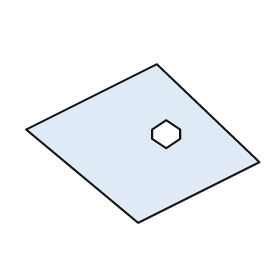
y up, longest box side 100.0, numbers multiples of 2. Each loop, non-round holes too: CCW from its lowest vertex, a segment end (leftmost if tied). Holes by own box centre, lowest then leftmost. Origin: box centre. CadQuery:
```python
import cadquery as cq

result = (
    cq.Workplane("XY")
    .moveTo(-2.0, -34.0)
    .lineTo(50.0, -8.0)
    .lineTo(6.0, 34.0)
    .lineTo(-50.0, 6.0)
    .close()
    .moveTo(10.0, -2.0)
    .lineTo(16.0, 2.0)
    .lineTo(16.0, 6.0)
    .lineTo(10.0, 10.0)
    .lineTo(4.0, 6.0)
    .lineTo(4.0, 2.0)
    .close()
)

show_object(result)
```